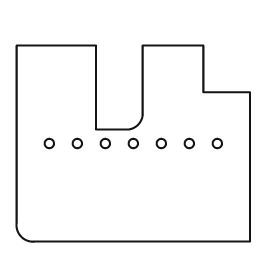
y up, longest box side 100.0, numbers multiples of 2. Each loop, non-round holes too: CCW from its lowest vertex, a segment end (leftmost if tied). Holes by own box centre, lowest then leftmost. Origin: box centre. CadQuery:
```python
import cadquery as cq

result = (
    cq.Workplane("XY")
    .moveTo(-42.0, -42.0)
    .lineTo(50.0, -42.0)
    .lineTo(50.0, 22.0)
    .lineTo(30.0, 22.0)
    .lineTo(30.0, 42.0)
    .lineTo(4.0, 42.0)
    .lineTo(4.0, 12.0)
    .threePointArc((2.0, 8.0), (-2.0, 6.0))
    .lineTo(-16.0, 6.0)
    .lineTo(-16.0, 42.0)
    .lineTo(-50.0, 42.0)
    .lineTo(-50.0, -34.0)
    .threePointArc((-48.0, -40.0), (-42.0, -42.0))
    .close()
    .moveTo(-36.0, 0.0)
    .circle(2.0)
    .moveTo(-24.0, 0.0)
    .circle(2.0)
    .moveTo(-12.0, 0.0)
    .circle(2.0)
    .moveTo(0.0, 0.0)
    .circle(2.0)
    .moveTo(12.0, 0.0)
    .circle(2.0)
    .moveTo(24.0, 0.0)
    .circle(2.0)
    .moveTo(36.0, 0.0)
    .circle(2.0)
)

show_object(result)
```